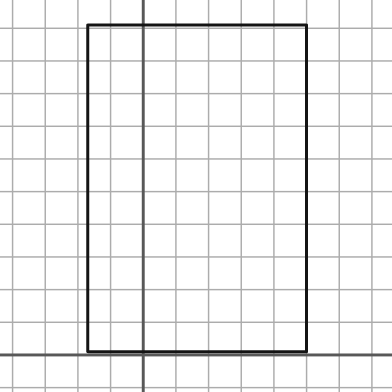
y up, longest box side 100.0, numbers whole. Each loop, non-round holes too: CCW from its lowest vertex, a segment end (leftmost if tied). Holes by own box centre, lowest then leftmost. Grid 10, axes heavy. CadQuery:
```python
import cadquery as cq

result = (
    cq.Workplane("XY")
    .moveTo(-17.0, 1.0)
    .lineTo(50.0, 1.0)
    .lineTo(50.0, 101.0)
    .lineTo(-17.0, 101.0)
    .close()
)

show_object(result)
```